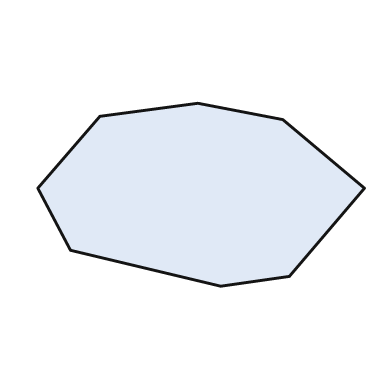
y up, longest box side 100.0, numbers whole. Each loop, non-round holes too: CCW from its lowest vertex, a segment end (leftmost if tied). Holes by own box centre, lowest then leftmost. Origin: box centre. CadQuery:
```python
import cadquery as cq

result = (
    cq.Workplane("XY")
    .moveTo(6.0, -28.0)
    .lineTo(27.0, -25.0)
    .lineTo(50.0, 2.0)
    .lineTo(25.0, 23.0)
    .lineTo(-1.0, 28.0)
    .lineTo(-31.0, 24.0)
    .lineTo(-50.0, 2.0)
    .lineTo(-40.0, -17.0)
    .close()
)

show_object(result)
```